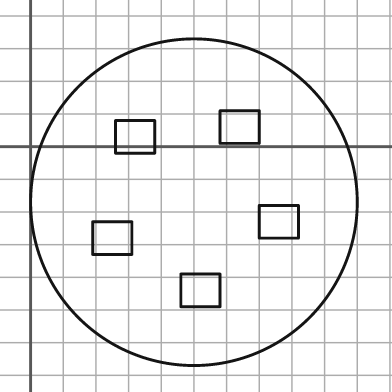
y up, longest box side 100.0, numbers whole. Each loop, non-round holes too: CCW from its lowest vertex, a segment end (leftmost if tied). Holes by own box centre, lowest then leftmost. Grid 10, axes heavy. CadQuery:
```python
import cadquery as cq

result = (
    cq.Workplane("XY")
    .moveTo(50.0, -17.0)
    .circle(50.0)
    .moveTo(46.0, -49.0)
    .lineTo(58.0, -49.0)
    .lineTo(58.0, -39.0)
    .lineTo(46.0, -39.0)
    .close()
    .moveTo(19.0, -33.0)
    .lineTo(31.0, -33.0)
    .lineTo(31.0, -23.0)
    .lineTo(19.0, -23.0)
    .close()
    .moveTo(70.0, -28.0)
    .lineTo(82.0, -28.0)
    .lineTo(82.0, -18.0)
    .lineTo(70.0, -18.0)
    .close()
    .moveTo(26.0, -2.0)
    .lineTo(38.0, -2.0)
    .lineTo(38.0, 8.0)
    .lineTo(26.0, 8.0)
    .close()
    .moveTo(58.0, 1.0)
    .lineTo(70.0, 1.0)
    .lineTo(70.0, 11.0)
    .lineTo(58.0, 11.0)
    .close()
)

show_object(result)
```